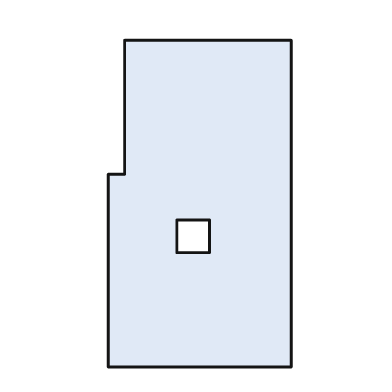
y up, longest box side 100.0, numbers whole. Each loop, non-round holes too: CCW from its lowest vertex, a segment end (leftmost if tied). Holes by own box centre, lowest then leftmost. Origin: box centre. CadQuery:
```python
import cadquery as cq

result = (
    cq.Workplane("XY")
    .moveTo(-28.0, -50.0)
    .lineTo(28.0, -50.0)
    .lineTo(28.0, 50.0)
    .lineTo(-23.0, 50.0)
    .lineTo(-23.0, 9.0)
    .lineTo(-28.0, 9.0)
    .close()
    .moveTo(-7.0, -15.0)
    .lineTo(3.0, -15.0)
    .lineTo(3.0, -5.0)
    .lineTo(-7.0, -5.0)
    .close()
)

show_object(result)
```